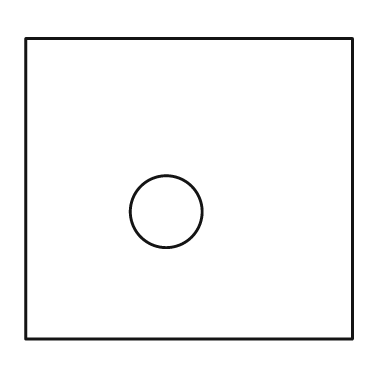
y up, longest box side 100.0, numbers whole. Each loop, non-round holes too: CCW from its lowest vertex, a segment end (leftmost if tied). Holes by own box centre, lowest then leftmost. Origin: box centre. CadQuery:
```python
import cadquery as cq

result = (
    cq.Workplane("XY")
    .moveTo(-50.0, -46.0)
    .lineTo(50.0, -46.0)
    .lineTo(50.0, 46.0)
    .lineTo(-50.0, 46.0)
    .close()
    .moveTo(-7.0, -7.0)
    .circle(11.0)
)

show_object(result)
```